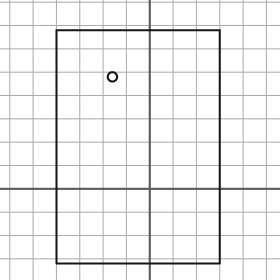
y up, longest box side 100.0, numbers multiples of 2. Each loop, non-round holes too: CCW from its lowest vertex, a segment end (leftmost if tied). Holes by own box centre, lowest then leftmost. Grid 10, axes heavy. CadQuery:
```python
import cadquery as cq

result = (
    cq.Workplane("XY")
    .moveTo(-40.0, -32.0)
    .lineTo(30.0, -32.0)
    .lineTo(30.0, 68.0)
    .lineTo(-40.0, 68.0)
    .close()
    .moveTo(-16.0, 48.0)
    .circle(2.0)
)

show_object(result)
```